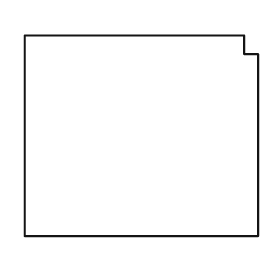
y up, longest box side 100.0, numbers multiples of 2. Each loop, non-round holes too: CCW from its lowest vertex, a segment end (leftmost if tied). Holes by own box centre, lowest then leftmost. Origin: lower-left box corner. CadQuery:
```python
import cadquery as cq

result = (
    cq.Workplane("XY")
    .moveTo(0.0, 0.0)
    .lineTo(100.0, 0.0)
    .lineTo(100.0, 78.0)
    .lineTo(94.0, 78.0)
    .lineTo(94.0, 86.0)
    .lineTo(0.0, 86.0)
    .close()
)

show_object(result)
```